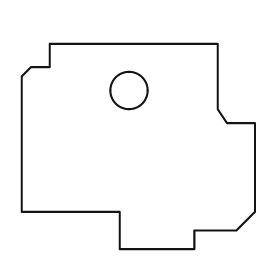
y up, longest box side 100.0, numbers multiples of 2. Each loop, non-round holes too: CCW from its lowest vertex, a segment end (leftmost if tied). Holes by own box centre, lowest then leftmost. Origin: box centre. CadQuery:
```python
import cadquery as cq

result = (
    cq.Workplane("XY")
    .moveTo(-8.0, -44.0)
    .lineTo(24.0, -44.0)
    .lineTo(24.0, -36.0)
    .lineTo(42.0, -36.0)
    .lineTo(50.0, -28.0)
    .lineTo(50.0, 10.0)
    .lineTo(38.0, 10.0)
    .lineTo(34.0, 16.0)
    .lineTo(34.0, 44.0)
    .lineTo(-38.0, 44.0)
    .lineTo(-38.0, 34.0)
    .lineTo(-46.0, 34.0)
    .lineTo(-50.0, 30.0)
    .lineTo(-50.0, -28.0)
    .lineTo(-8.0, -28.0)
    .close()
    .moveTo(-4.0, 24.0)
    .circle(8.0)
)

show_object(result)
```